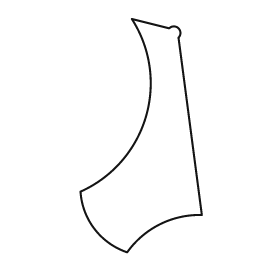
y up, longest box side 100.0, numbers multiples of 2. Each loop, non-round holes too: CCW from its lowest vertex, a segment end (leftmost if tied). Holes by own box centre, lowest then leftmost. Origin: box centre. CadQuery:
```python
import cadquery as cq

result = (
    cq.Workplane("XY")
    .moveTo(-6.0, -50.0)
    .threePointArc((8.0, -38.0), (26.0, -34.0))
    .lineTo(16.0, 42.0)
    .threePointArc((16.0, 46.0), (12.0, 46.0))
    .lineTo(-4.0, 50.0)
    .threePointArc((2.0, 8.0), (-26.0, -24.0))
    .threePointArc((-20.0, -40.0), (-6.0, -50.0))
    .close()
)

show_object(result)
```